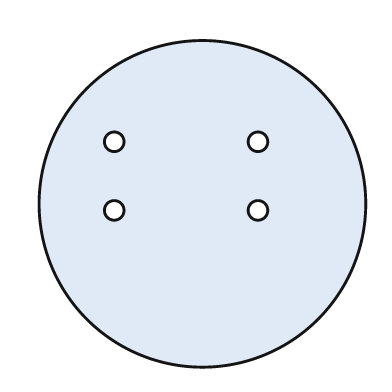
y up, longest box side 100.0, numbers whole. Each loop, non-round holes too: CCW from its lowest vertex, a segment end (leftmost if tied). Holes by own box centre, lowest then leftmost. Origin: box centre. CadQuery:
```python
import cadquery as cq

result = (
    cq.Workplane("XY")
    .moveTo(0.0, 0.0)
    .circle(50.0)
    .moveTo(-27.0, -2.0)
    .circle(3.0)
    .moveTo(17.0, -2.0)
    .circle(3.0)
    .moveTo(-27.0, 19.0)
    .circle(3.0)
    .moveTo(17.0, 19.0)
    .circle(3.0)
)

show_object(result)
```